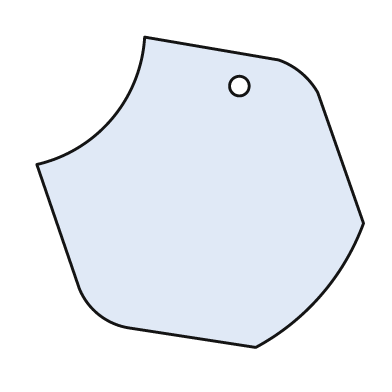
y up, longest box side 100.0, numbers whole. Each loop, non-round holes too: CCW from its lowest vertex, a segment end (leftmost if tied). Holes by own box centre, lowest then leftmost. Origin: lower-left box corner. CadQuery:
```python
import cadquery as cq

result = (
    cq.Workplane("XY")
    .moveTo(67.0, 0.0)
    .threePointArc((87.0, 16.0), (100.0, 38.0))
    .lineTo(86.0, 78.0)
    .threePointArc((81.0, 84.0), (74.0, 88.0))
    .lineTo(33.0, 95.0)
    .threePointArc((23.0, 70.0), (0.0, 56.0))
    .lineTo(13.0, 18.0)
    .threePointArc((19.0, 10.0), (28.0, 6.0))
    .close()
    .moveTo(62.0, 80.0)
    .circle(3.0)
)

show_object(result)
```